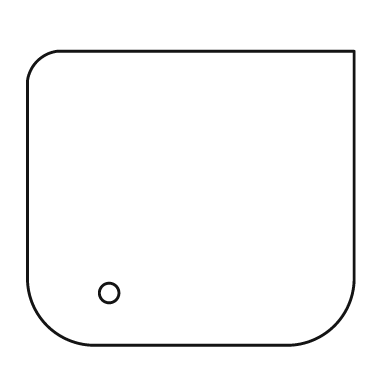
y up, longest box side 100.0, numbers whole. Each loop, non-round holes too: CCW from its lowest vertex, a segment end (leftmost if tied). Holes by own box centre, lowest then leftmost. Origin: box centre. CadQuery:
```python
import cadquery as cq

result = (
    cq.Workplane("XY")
    .moveTo(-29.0, -45.0)
    .lineTo(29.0, -45.0)
    .threePointArc((44.0, -39.0), (50.0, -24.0))
    .lineTo(50.0, 45.0)
    .lineTo(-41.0, 45.0)
    .threePointArc((-47.0, 42.0), (-50.0, 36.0))
    .lineTo(-50.0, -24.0)
    .threePointArc((-44.0, -39.0), (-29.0, -45.0))
    .close()
    .moveTo(-25.0, -29.0)
    .circle(3.0)
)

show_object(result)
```